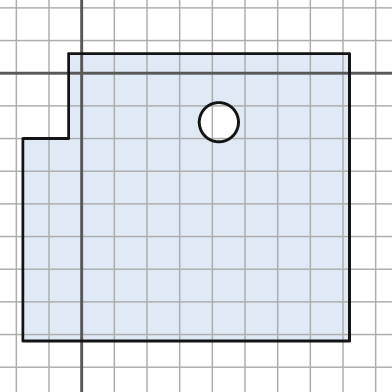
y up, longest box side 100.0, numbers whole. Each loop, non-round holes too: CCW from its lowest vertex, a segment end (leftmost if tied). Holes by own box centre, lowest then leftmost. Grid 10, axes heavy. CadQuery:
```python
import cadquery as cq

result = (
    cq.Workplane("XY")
    .moveTo(-18.0, -82.0)
    .lineTo(82.0, -82.0)
    .lineTo(82.0, 6.0)
    .lineTo(-4.0, 6.0)
    .lineTo(-4.0, -20.0)
    .lineTo(-18.0, -20.0)
    .close()
    .moveTo(42.0, -15.0)
    .circle(6.0)
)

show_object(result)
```